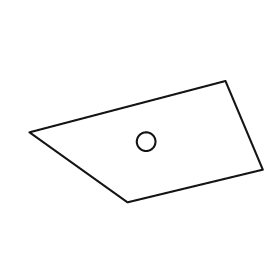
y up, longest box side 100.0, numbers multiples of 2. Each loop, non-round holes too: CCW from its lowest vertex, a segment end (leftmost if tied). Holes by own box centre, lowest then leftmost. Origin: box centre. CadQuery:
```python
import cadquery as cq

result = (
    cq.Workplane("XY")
    .moveTo(-8.0, -26.0)
    .lineTo(50.0, -12.0)
    .lineTo(34.0, 26.0)
    .lineTo(-50.0, 4.0)
    .close()
    .moveTo(0.0, 0.0)
    .circle(4.0)
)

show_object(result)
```